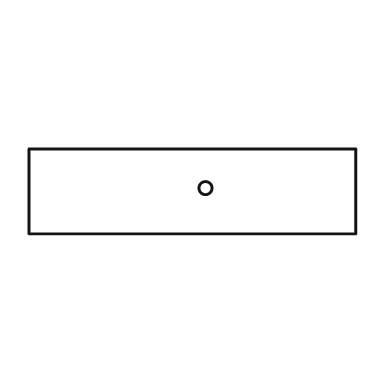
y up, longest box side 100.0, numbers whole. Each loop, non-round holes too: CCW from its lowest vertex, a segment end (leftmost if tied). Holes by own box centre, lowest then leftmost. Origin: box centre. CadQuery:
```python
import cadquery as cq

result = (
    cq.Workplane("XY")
    .moveTo(-50.0, -13.0)
    .lineTo(50.0, -13.0)
    .lineTo(50.0, 13.0)
    .lineTo(-50.0, 13.0)
    .close()
    .moveTo(4.0, 1.0)
    .circle(2.0)
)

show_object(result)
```